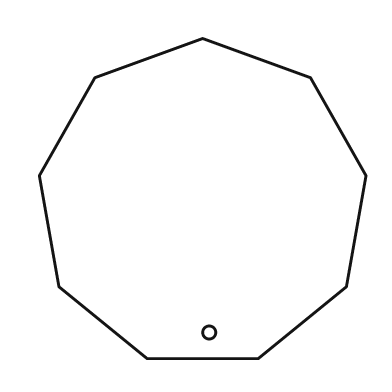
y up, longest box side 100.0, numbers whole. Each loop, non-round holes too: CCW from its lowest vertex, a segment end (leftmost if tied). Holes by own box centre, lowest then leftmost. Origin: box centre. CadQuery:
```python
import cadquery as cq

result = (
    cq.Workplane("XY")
    .moveTo(-17.0, -49.0)
    .lineTo(17.0, -49.0)
    .lineTo(44.0, -27.0)
    .lineTo(50.0, 7.0)
    .lineTo(33.0, 37.0)
    .lineTo(0.0, 49.0)
    .lineTo(-33.0, 37.0)
    .lineTo(-50.0, 7.0)
    .lineTo(-44.0, -27.0)
    .close()
    .moveTo(2.0, -41.0)
    .circle(2.0)
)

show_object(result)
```